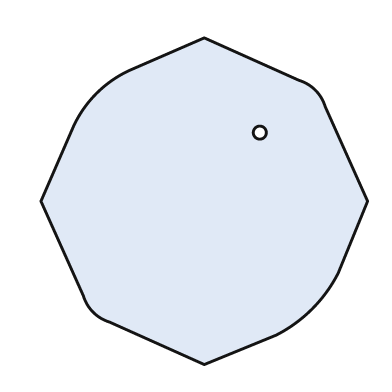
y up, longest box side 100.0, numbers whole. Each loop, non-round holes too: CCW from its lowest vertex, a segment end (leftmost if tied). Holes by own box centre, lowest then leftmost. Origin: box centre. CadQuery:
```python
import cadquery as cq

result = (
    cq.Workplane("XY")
    .moveTo(0.0, -50.0)
    .lineTo(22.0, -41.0)
    .threePointArc((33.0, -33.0), (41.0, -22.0))
    .lineTo(50.0, 0.0)
    .lineTo(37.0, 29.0)
    .threePointArc((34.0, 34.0), (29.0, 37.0))
    .lineTo(0.0, 50.0)
    .lineTo(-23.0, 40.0)
    .threePointArc((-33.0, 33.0), (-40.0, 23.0))
    .lineTo(-50.0, 0.0)
    .lineTo(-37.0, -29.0)
    .threePointArc((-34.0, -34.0), (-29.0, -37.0))
    .close()
    .moveTo(17.0, 21.0)
    .circle(2.0)
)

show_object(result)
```